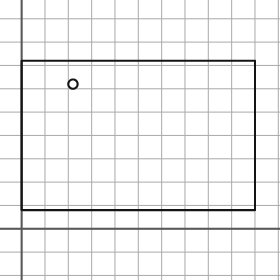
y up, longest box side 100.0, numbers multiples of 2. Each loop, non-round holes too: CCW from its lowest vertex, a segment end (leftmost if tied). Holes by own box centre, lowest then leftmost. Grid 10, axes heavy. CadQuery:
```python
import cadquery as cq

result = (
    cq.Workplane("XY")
    .moveTo(0.0, 8.0)
    .lineTo(100.0, 8.0)
    .lineTo(100.0, 72.0)
    .lineTo(0.0, 72.0)
    .close()
    .moveTo(22.0, 62.0)
    .circle(2.0)
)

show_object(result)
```